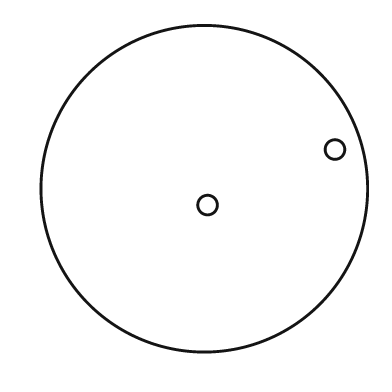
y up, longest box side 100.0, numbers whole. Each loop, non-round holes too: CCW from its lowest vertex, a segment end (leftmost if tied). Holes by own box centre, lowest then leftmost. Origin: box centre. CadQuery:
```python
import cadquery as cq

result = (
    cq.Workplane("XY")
    .moveTo(0.0, 0.0)
    .circle(50.0)
    .moveTo(1.0, -5.0)
    .circle(3.0)
    .moveTo(40.0, 12.0)
    .circle(3.0)
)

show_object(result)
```